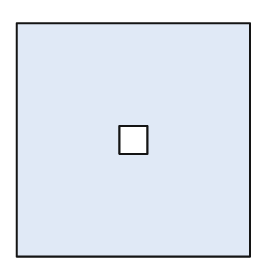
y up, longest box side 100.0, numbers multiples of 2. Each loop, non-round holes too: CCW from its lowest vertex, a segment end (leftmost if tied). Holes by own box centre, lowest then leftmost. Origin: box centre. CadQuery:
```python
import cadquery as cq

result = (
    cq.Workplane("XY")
    .moveTo(-50.0, -50.0)
    .lineTo(50.0, -50.0)
    .lineTo(50.0, 50.0)
    .lineTo(-50.0, 50.0)
    .close()
    .moveTo(-6.0, -6.0)
    .lineTo(6.0, -6.0)
    .lineTo(6.0, 6.0)
    .lineTo(-6.0, 6.0)
    .close()
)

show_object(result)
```